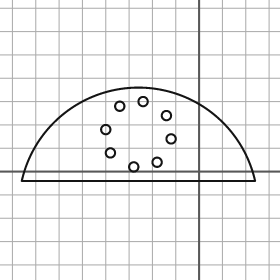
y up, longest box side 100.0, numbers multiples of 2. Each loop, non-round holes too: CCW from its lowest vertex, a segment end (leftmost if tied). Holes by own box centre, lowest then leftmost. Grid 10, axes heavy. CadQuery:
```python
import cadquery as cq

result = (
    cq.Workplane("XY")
    .moveTo(-76.0, -4.0)
    .lineTo(24.0, -4.0)
    .threePointArc((-26.0, 36.0), (-76.0, -4.0))
    .close()
    .moveTo(-28.0, 2.0)
    .circle(2.0)
    .moveTo(-18.0, 4.0)
    .circle(2.0)
    .moveTo(-38.0, 8.0)
    .circle(2.0)
    .moveTo(-12.0, 14.0)
    .circle(2.0)
    .moveTo(-40.0, 18.0)
    .circle(2.0)
    .moveTo(-14.0, 24.0)
    .circle(2.0)
    .moveTo(-34.0, 28.0)
    .circle(2.0)
    .moveTo(-24.0, 30.0)
    .circle(2.0)
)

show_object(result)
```